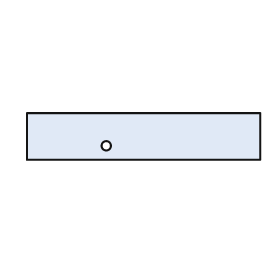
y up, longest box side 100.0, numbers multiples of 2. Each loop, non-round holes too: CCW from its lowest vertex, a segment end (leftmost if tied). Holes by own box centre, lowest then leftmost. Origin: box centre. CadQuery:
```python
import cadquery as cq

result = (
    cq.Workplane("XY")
    .moveTo(-50.0, -10.0)
    .lineTo(50.0, -10.0)
    .lineTo(50.0, 10.0)
    .lineTo(-50.0, 10.0)
    .close()
    .moveTo(-16.0, -4.0)
    .circle(2.0)
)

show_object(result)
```